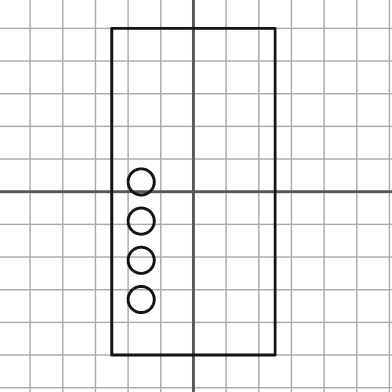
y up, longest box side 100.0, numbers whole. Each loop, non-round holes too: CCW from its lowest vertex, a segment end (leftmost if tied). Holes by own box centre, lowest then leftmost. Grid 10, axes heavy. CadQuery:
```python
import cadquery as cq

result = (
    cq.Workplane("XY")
    .moveTo(-25.0, -50.0)
    .lineTo(25.0, -50.0)
    .lineTo(25.0, 50.0)
    .lineTo(-25.0, 50.0)
    .close()
    .moveTo(-16.0, -33.0)
    .circle(4.0)
    .moveTo(-16.0, -21.0)
    .circle(4.0)
    .moveTo(-16.0, -9.0)
    .circle(4.0)
    .moveTo(-16.0, 3.0)
    .circle(4.0)
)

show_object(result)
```